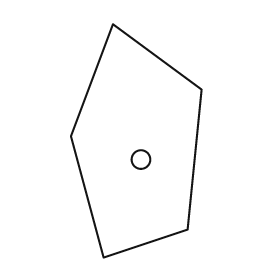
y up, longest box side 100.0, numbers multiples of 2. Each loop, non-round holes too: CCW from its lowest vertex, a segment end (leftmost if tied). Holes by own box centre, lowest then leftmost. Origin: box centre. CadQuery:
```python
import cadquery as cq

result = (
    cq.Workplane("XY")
    .moveTo(-14.0, -50.0)
    .lineTo(22.0, -38.0)
    .lineTo(28.0, 22.0)
    .lineTo(-10.0, 50.0)
    .lineTo(-28.0, 2.0)
    .close()
    .moveTo(2.0, -8.0)
    .circle(4.0)
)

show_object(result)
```